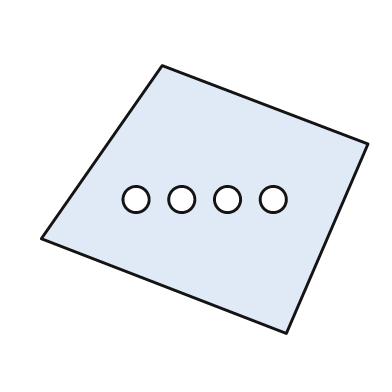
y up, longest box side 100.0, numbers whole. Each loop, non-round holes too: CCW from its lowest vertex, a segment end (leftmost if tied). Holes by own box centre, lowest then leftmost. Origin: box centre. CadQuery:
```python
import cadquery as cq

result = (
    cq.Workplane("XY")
    .moveTo(25.0, -41.0)
    .lineTo(50.0, 17.0)
    .lineTo(-13.0, 41.0)
    .lineTo(-50.0, -12.0)
    .close()
    .moveTo(-21.0, 0.0)
    .circle(4.0)
    .moveTo(-7.0, 0.0)
    .circle(4.0)
    .moveTo(7.0, 0.0)
    .circle(4.0)
    .moveTo(21.0, 0.0)
    .circle(4.0)
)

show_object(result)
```